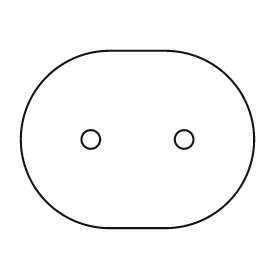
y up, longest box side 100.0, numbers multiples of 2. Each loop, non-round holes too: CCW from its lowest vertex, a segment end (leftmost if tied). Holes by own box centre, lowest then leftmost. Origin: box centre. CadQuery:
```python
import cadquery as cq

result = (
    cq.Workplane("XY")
    .moveTo(-12.0, -38.0)
    .lineTo(12.0, -38.0)
    .threePointArc((50.0, 0.0), (12.0, 38.0))
    .lineTo(-12.0, 38.0)
    .threePointArc((-50.0, 0.0), (-12.0, -38.0))
    .close()
    .moveTo(-20.0, 0.0)
    .circle(4.0)
    .moveTo(20.0, 0.0)
    .circle(4.0)
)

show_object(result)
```